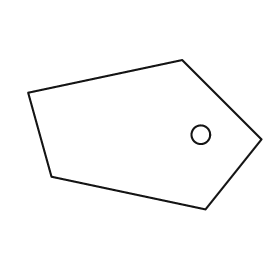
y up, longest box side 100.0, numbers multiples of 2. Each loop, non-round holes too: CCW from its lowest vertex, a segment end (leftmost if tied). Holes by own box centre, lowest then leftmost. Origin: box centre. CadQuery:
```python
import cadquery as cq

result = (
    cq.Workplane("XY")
    .moveTo(26.0, -32.0)
    .lineTo(50.0, -2.0)
    .lineTo(16.0, 32.0)
    .lineTo(-50.0, 18.0)
    .lineTo(-40.0, -18.0)
    .close()
    .moveTo(24.0, 0.0)
    .circle(4.0)
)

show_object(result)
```